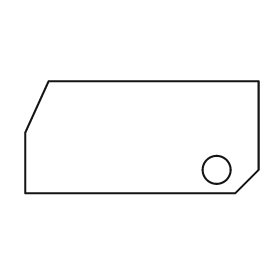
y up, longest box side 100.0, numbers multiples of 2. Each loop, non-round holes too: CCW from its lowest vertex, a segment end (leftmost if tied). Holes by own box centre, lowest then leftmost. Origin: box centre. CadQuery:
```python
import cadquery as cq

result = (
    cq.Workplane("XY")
    .moveTo(-50.0, -24.0)
    .lineTo(40.0, -24.0)
    .lineTo(50.0, -14.0)
    .lineTo(50.0, 24.0)
    .lineTo(-40.0, 24.0)
    .lineTo(-50.0, 2.0)
    .close()
    .moveTo(32.0, -14.0)
    .circle(6.0)
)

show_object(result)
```